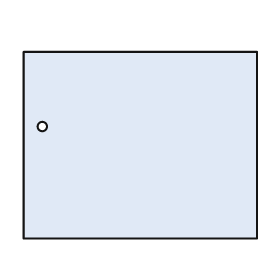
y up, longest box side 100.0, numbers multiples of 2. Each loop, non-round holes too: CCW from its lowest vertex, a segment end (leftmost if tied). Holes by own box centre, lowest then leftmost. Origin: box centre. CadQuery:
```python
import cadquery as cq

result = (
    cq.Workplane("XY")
    .moveTo(-50.0, -40.0)
    .lineTo(50.0, -40.0)
    .lineTo(50.0, 40.0)
    .lineTo(-50.0, 40.0)
    .close()
    .moveTo(-42.0, 8.0)
    .circle(2.0)
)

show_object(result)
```